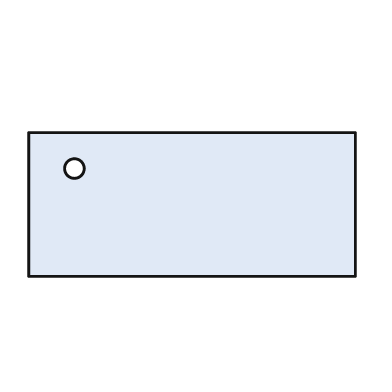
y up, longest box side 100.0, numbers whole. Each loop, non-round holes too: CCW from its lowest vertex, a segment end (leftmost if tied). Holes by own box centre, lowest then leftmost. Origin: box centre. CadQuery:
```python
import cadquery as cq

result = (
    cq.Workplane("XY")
    .moveTo(-50.0, -22.0)
    .lineTo(50.0, -22.0)
    .lineTo(50.0, 22.0)
    .lineTo(-50.0, 22.0)
    .close()
    .moveTo(-36.0, 11.0)
    .circle(3.0)
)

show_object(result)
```